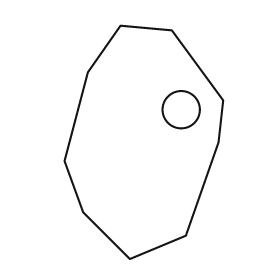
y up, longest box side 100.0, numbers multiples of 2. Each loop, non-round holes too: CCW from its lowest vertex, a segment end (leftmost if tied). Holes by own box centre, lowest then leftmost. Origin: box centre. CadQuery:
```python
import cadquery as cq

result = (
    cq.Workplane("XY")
    .moveTo(-6.0, -50.0)
    .lineTo(18.0, -40.0)
    .lineTo(32.0, 0.0)
    .lineTo(34.0, 18.0)
    .lineTo(12.0, 48.0)
    .lineTo(-10.0, 50.0)
    .lineTo(-24.0, 30.0)
    .lineTo(-34.0, -8.0)
    .lineTo(-26.0, -30.0)
    .close()
    .moveTo(16.0, 14.0)
    .circle(8.0)
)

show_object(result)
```